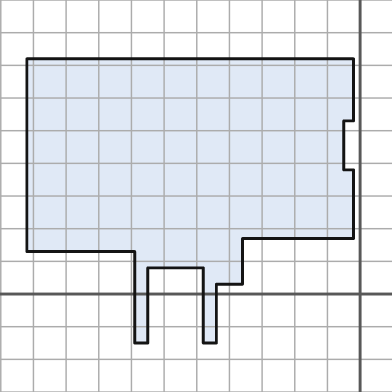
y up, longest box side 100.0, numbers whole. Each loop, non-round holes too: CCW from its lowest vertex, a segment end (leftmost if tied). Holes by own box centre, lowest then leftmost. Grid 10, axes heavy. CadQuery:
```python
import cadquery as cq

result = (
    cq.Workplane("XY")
    .moveTo(-69.0, -15.0)
    .lineTo(-65.0, -15.0)
    .lineTo(-65.0, 8.0)
    .lineTo(-48.0, 8.0)
    .lineTo(-48.0, -15.0)
    .lineTo(-44.0, -15.0)
    .lineTo(-44.0, 3.0)
    .lineTo(-36.0, 3.0)
    .lineTo(-36.0, 17.0)
    .lineTo(-2.0, 17.0)
    .lineTo(-2.0, 38.0)
    .lineTo(-5.0, 38.0)
    .lineTo(-5.0, 53.0)
    .lineTo(-2.0, 53.0)
    .lineTo(-2.0, 72.0)
    .lineTo(-102.0, 72.0)
    .lineTo(-102.0, 13.0)
    .lineTo(-69.0, 13.0)
    .close()
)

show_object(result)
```